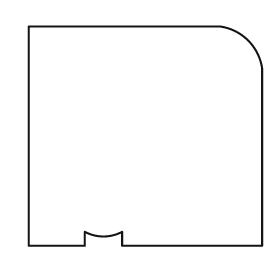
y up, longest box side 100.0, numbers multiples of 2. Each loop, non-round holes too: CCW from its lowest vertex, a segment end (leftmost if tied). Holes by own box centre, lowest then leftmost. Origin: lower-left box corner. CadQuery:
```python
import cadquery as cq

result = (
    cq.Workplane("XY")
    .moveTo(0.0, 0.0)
    .lineTo(24.0, 0.0)
    .lineTo(24.0, 6.0)
    .threePointArc((32.0, 4.0), (40.0, 6.0))
    .lineTo(40.0, 0.0)
    .lineTo(100.0, 0.0)
    .lineTo(100.0, 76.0)
    .threePointArc((94.0, 88.0), (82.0, 94.0))
    .lineTo(0.0, 94.0)
    .close()
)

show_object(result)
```